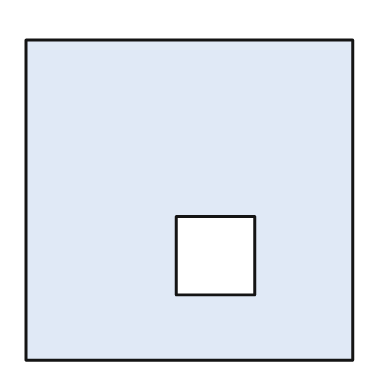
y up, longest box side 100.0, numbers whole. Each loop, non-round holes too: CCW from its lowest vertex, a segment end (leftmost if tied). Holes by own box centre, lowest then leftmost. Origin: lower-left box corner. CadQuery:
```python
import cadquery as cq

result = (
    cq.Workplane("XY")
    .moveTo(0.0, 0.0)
    .lineTo(100.0, 0.0)
    .lineTo(100.0, 98.0)
    .lineTo(0.0, 98.0)
    .close()
    .moveTo(46.0, 20.0)
    .lineTo(70.0, 20.0)
    .lineTo(70.0, 44.0)
    .lineTo(46.0, 44.0)
    .close()
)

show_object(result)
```